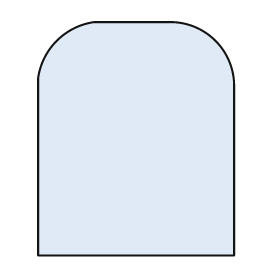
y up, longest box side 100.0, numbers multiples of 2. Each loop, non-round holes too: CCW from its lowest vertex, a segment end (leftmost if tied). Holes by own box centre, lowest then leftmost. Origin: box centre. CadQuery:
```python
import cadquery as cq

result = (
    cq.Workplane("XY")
    .moveTo(-42.0, -50.0)
    .lineTo(42.0, -50.0)
    .lineTo(42.0, 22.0)
    .threePointArc((34.0, 42.0), (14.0, 50.0))
    .lineTo(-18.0, 50.0)
    .threePointArc((-34.0, 42.0), (-42.0, 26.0))
    .close()
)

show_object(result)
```